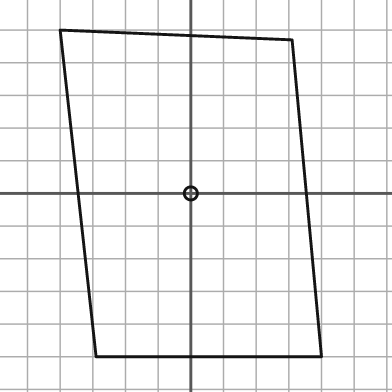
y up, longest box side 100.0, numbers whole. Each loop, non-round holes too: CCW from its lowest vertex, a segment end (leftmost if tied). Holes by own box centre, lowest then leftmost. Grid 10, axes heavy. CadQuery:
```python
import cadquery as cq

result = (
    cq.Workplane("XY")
    .moveTo(-29.0, -50.0)
    .lineTo(40.0, -50.0)
    .lineTo(31.0, 47.0)
    .lineTo(-40.0, 50.0)
    .close()
    .moveTo(0.0, 0.0)
    .circle(2.0)
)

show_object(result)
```